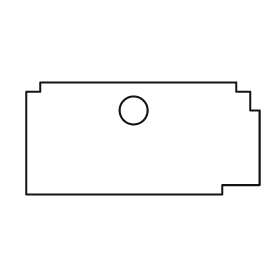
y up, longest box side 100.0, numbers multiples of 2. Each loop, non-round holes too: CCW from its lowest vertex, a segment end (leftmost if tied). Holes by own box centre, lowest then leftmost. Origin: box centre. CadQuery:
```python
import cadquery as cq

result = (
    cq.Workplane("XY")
    .moveTo(-50.0, -24.0)
    .lineTo(34.0, -24.0)
    .lineTo(34.0, -20.0)
    .lineTo(50.0, -20.0)
    .lineTo(50.0, 12.0)
    .lineTo(46.0, 12.0)
    .lineTo(46.0, 20.0)
    .lineTo(40.0, 20.0)
    .lineTo(40.0, 24.0)
    .lineTo(-44.0, 24.0)
    .lineTo(-44.0, 20.0)
    .lineTo(-50.0, 20.0)
    .close()
    .moveTo(-4.0, 12.0)
    .circle(6.0)
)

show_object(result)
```